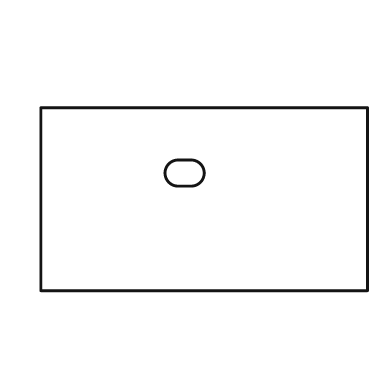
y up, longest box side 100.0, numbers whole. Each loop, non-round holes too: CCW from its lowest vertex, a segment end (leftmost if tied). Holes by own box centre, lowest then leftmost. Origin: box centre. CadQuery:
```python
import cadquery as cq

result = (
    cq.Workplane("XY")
    .moveTo(-50.0, -28.0)
    .lineTo(50.0, -28.0)
    .lineTo(50.0, 28.0)
    .lineTo(-50.0, 28.0)
    .close()
    .moveTo(-8.0, 4.0)
    .lineTo(-4.0, 4.0)
    .threePointArc((0.0, 8.0), (-4.0, 12.0))
    .lineTo(-8.0, 12.0)
    .threePointArc((-12.0, 8.0), (-8.0, 4.0))
    .close()
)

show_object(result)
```